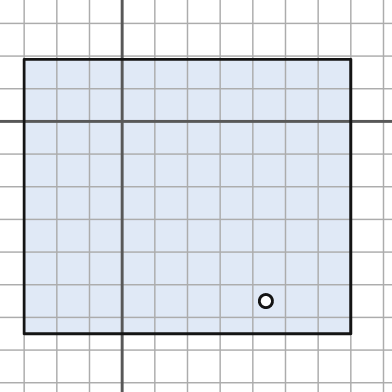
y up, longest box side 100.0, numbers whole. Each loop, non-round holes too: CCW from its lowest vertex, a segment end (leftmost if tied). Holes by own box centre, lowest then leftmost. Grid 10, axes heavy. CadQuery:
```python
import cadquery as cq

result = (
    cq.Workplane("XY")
    .moveTo(-30.0, -65.0)
    .lineTo(70.0, -65.0)
    .lineTo(70.0, 19.0)
    .lineTo(-30.0, 19.0)
    .close()
    .moveTo(44.0, -55.0)
    .circle(2.0)
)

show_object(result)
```